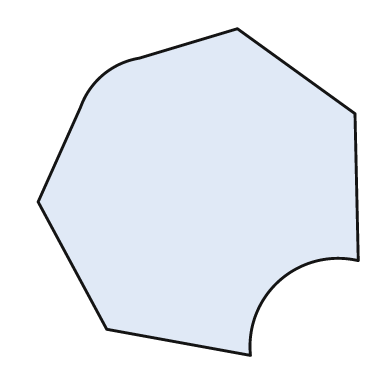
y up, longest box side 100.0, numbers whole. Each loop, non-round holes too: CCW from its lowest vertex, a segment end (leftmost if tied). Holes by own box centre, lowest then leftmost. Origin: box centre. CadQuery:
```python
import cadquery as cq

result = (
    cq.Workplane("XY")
    .moveTo(16.0, -50.0)
    .threePointArc((25.0, -27.0), (49.0, -21.0))
    .lineTo(48.0, 24.0)
    .lineTo(12.0, 50.0)
    .lineTo(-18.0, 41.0)
    .threePointArc((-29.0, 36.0), (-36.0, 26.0))
    .lineTo(-49.0, -3.0)
    .lineTo(-28.0, -42.0)
    .close()
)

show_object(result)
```